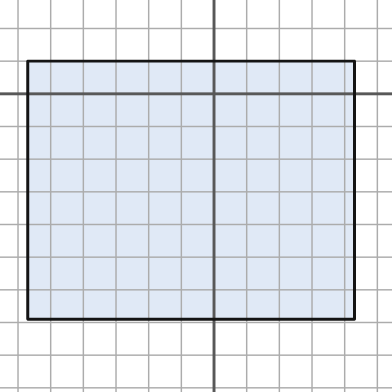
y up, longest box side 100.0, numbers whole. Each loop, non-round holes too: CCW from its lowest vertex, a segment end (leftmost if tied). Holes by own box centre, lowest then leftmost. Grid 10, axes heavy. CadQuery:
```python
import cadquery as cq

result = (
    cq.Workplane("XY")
    .moveTo(-57.0, -69.0)
    .lineTo(43.0, -69.0)
    .lineTo(43.0, 10.0)
    .lineTo(-57.0, 10.0)
    .close()
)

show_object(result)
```